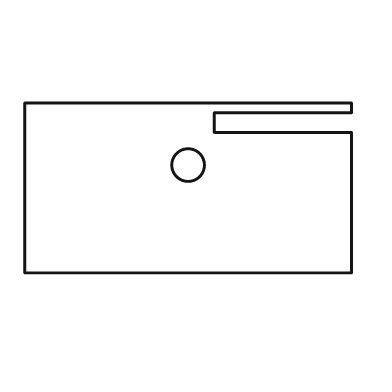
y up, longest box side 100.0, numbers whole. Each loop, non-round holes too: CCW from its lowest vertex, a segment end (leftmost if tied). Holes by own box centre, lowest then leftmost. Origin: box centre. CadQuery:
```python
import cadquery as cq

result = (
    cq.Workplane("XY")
    .moveTo(-50.0, -26.0)
    .lineTo(50.0, -26.0)
    .lineTo(50.0, 17.0)
    .lineTo(8.0, 17.0)
    .lineTo(8.0, 23.0)
    .lineTo(50.0, 23.0)
    .lineTo(50.0, 26.0)
    .lineTo(-50.0, 26.0)
    .close()
    .moveTo(0.0, 7.0)
    .circle(5.0)
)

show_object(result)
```